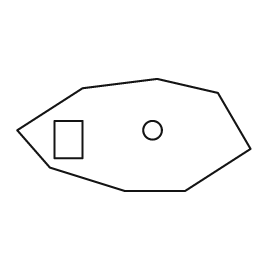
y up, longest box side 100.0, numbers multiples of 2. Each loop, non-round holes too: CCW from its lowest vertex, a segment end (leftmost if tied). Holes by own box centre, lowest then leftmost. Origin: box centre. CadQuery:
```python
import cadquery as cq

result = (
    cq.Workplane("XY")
    .moveTo(-4.0, -24.0)
    .lineTo(22.0, -24.0)
    .lineTo(50.0, -6.0)
    .lineTo(36.0, 18.0)
    .lineTo(10.0, 24.0)
    .lineTo(-22.0, 20.0)
    .lineTo(-50.0, 2.0)
    .lineTo(-36.0, -14.0)
    .close()
    .moveTo(-34.0, -10.0)
    .lineTo(-22.0, -10.0)
    .lineTo(-22.0, 6.0)
    .lineTo(-34.0, 6.0)
    .close()
    .moveTo(8.0, 2.0)
    .circle(4.0)
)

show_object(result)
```